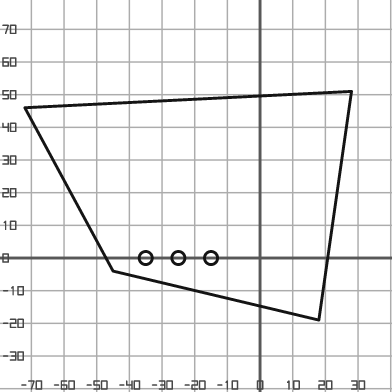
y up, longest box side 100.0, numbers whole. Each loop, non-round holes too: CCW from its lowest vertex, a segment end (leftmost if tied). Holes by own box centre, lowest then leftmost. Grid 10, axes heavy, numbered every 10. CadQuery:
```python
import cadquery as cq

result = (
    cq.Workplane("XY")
    .moveTo(18.0, -19.0)
    .lineTo(28.0, 51.0)
    .lineTo(-72.0, 46.0)
    .lineTo(-45.0, -4.0)
    .close()
    .moveTo(-35.0, 0.0)
    .circle(2.0)
    .moveTo(-25.0, 0.0)
    .circle(2.0)
    .moveTo(-15.0, 0.0)
    .circle(2.0)
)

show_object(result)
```